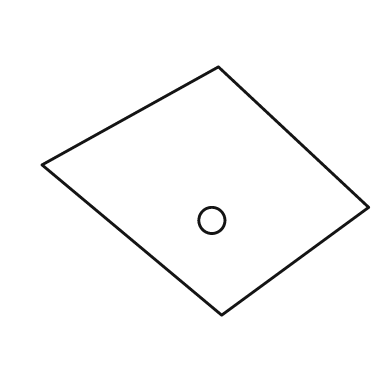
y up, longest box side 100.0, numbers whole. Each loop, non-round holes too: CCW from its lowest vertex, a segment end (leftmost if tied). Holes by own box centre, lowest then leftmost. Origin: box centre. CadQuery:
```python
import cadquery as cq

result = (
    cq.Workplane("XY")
    .moveTo(5.0, -38.0)
    .lineTo(50.0, -5.0)
    .lineTo(4.0, 38.0)
    .lineTo(-50.0, 8.0)
    .close()
    .moveTo(2.0, -9.0)
    .circle(4.0)
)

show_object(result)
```